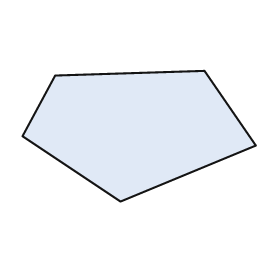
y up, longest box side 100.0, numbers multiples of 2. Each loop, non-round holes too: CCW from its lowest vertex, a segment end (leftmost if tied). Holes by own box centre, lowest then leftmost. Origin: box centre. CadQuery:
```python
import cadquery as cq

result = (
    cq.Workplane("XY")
    .moveTo(-8.0, -28.0)
    .lineTo(50.0, -4.0)
    .lineTo(28.0, 28.0)
    .lineTo(-36.0, 26.0)
    .lineTo(-50.0, 0.0)
    .close()
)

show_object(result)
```